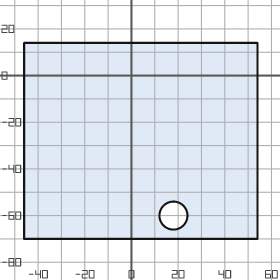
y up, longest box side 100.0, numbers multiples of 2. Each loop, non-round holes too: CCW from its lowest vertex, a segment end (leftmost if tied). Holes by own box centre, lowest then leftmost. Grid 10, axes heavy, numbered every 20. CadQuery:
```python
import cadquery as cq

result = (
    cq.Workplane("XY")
    .moveTo(-46.0, -70.0)
    .lineTo(54.0, -70.0)
    .lineTo(54.0, 14.0)
    .lineTo(-46.0, 14.0)
    .close()
    .moveTo(18.0, -60.0)
    .circle(6.0)
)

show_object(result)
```